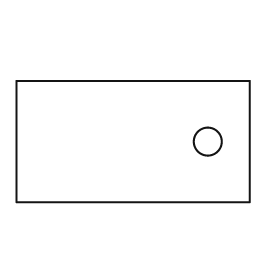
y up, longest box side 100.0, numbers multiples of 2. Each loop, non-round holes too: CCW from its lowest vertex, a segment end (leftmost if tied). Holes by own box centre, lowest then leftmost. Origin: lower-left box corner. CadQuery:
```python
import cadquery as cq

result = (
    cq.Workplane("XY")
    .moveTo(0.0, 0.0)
    .lineTo(100.0, 0.0)
    .lineTo(100.0, 52.0)
    .lineTo(0.0, 52.0)
    .close()
    .moveTo(82.0, 26.0)
    .circle(6.0)
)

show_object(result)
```